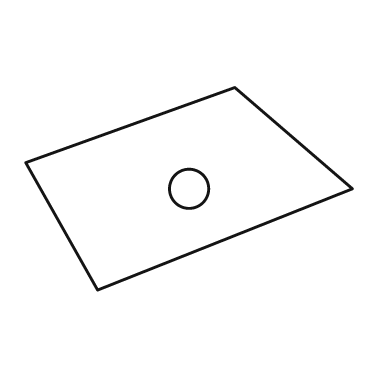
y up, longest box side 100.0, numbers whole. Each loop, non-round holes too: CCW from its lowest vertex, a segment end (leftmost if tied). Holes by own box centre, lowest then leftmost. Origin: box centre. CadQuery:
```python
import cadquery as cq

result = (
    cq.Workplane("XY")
    .moveTo(-28.0, -31.0)
    .lineTo(50.0, 0.0)
    .lineTo(14.0, 31.0)
    .lineTo(-50.0, 8.0)
    .close()
    .moveTo(0.0, 0.0)
    .circle(6.0)
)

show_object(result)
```